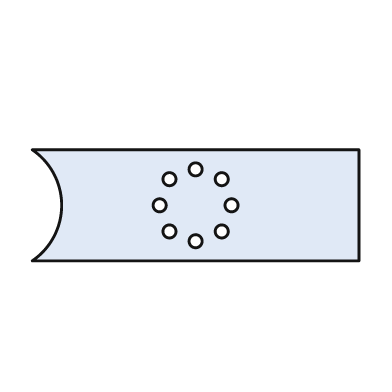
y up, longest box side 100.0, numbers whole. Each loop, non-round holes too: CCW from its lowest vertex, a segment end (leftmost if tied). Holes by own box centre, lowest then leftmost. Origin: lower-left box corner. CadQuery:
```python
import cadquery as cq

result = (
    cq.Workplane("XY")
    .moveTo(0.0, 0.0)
    .lineTo(100.0, 0.0)
    .lineTo(100.0, 34.0)
    .lineTo(0.0, 34.0)
    .threePointArc((9.0, 17.0), (0.0, 0.0))
    .close()
    .moveTo(50.0, 6.0)
    .circle(2.0)
    .moveTo(42.0, 9.0)
    .circle(2.0)
    .moveTo(58.0, 9.0)
    .circle(2.0)
    .moveTo(39.0, 17.0)
    .circle(2.0)
    .moveTo(61.0, 17.0)
    .circle(2.0)
    .moveTo(42.0, 25.0)
    .circle(2.0)
    .moveTo(58.0, 25.0)
    .circle(2.0)
    .moveTo(50.0, 28.0)
    .circle(2.0)
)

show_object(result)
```